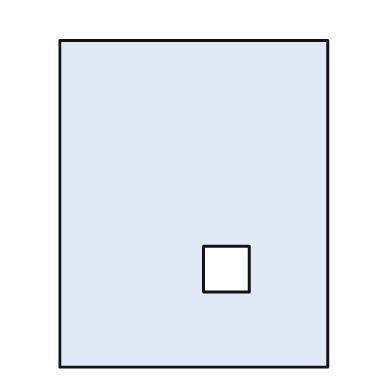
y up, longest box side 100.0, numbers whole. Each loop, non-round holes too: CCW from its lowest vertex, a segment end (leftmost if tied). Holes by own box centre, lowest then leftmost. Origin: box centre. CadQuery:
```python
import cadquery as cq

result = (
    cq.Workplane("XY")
    .moveTo(-41.0, -50.0)
    .lineTo(41.0, -50.0)
    .lineTo(41.0, 50.0)
    .lineTo(-41.0, 50.0)
    .close()
    .moveTo(3.0, -27.0)
    .lineTo(17.0, -27.0)
    .lineTo(17.0, -13.0)
    .lineTo(3.0, -13.0)
    .close()
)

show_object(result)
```